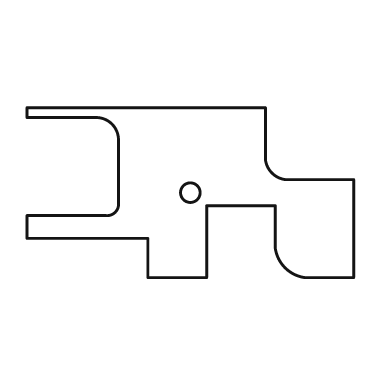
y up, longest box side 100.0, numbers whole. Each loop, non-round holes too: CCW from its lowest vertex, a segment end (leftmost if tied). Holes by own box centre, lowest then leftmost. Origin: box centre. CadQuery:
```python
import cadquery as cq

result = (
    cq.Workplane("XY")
    .moveTo(-13.0, -26.0)
    .lineTo(5.0, -26.0)
    .lineTo(5.0, -4.0)
    .lineTo(26.0, -4.0)
    .lineTo(26.0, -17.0)
    .threePointArc((29.0, -23.0), (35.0, -26.0))
    .lineTo(50.0, -26.0)
    .lineTo(50.0, 4.0)
    .lineTo(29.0, 4.0)
    .threePointArc((25.0, 6.0), (23.0, 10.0))
    .lineTo(23.0, 26.0)
    .lineTo(-50.0, 26.0)
    .lineTo(-50.0, 23.0)
    .lineTo(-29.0, 23.0)
    .threePointArc((-24.0, 21.0), (-22.0, 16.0))
    .lineTo(-22.0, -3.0)
    .threePointArc((-23.0, -6.0), (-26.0, -7.0))
    .lineTo(-50.0, -7.0)
    .lineTo(-50.0, -14.0)
    .lineTo(-13.0, -14.0)
    .close()
    .moveTo(0.0, 0.0)
    .circle(3.0)
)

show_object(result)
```